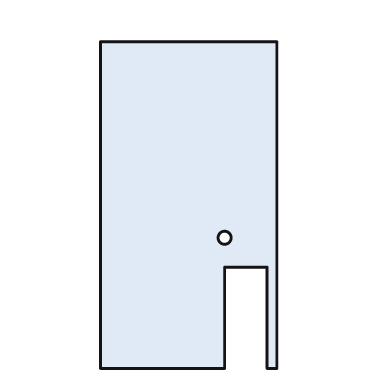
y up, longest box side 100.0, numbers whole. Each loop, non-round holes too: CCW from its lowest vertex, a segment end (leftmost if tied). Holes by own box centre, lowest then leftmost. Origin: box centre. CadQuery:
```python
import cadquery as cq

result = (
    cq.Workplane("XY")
    .moveTo(-27.0, -50.0)
    .lineTo(11.0, -50.0)
    .lineTo(11.0, -19.0)
    .lineTo(24.0, -19.0)
    .lineTo(24.0, -50.0)
    .lineTo(27.0, -50.0)
    .lineTo(27.0, 50.0)
    .lineTo(-27.0, 50.0)
    .close()
    .moveTo(11.0, -10.0)
    .circle(2.0)
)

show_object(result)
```